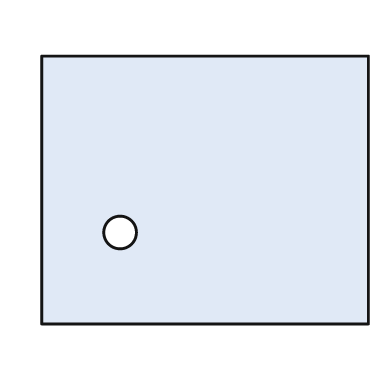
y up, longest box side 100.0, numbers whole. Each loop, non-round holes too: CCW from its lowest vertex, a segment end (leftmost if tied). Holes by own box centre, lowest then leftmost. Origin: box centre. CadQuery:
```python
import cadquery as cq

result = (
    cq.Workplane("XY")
    .moveTo(-50.0, -41.0)
    .lineTo(50.0, -41.0)
    .lineTo(50.0, 41.0)
    .lineTo(-50.0, 41.0)
    .close()
    .moveTo(-26.0, -13.0)
    .circle(5.0)
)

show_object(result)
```